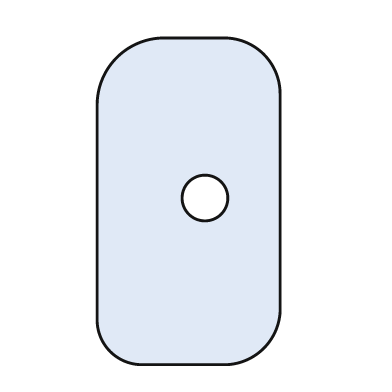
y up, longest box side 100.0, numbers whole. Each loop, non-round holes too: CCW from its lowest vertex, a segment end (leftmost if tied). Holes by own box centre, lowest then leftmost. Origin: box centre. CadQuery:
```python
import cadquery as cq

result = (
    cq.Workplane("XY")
    .moveTo(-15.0, -50.0)
    .lineTo(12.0, -50.0)
    .threePointArc((23.0, -45.0), (28.0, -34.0))
    .lineTo(28.0, 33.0)
    .threePointArc((23.0, 45.0), (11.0, 50.0))
    .lineTo(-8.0, 50.0)
    .threePointArc((-22.0, 44.0), (-28.0, 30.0))
    .lineTo(-28.0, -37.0)
    .threePointArc((-24.0, -46.0), (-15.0, -50.0))
    .close()
    .moveTo(5.0, 1.0)
    .circle(7.0)
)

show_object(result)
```